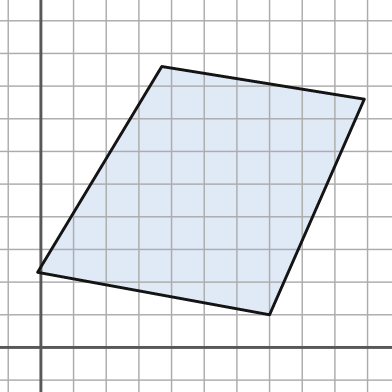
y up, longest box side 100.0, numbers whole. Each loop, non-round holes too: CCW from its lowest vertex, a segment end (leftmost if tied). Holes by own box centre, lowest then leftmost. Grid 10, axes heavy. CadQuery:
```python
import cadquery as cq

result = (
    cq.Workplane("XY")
    .moveTo(70.0, 10.0)
    .lineTo(99.0, 76.0)
    .lineTo(37.0, 86.0)
    .lineTo(-1.0, 23.0)
    .close()
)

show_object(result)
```